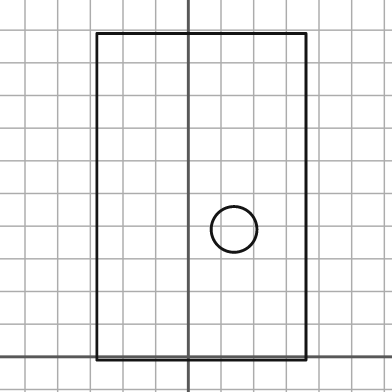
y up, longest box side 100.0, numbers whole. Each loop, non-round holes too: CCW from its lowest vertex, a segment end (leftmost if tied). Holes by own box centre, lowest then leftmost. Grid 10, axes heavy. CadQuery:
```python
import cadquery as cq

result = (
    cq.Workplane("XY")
    .moveTo(-28.0, -1.0)
    .lineTo(36.0, -1.0)
    .lineTo(36.0, 99.0)
    .lineTo(-28.0, 99.0)
    .close()
    .moveTo(14.0, 39.0)
    .circle(7.0)
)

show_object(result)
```